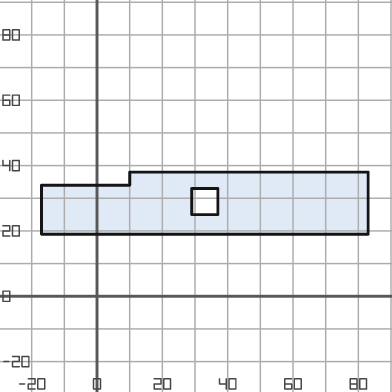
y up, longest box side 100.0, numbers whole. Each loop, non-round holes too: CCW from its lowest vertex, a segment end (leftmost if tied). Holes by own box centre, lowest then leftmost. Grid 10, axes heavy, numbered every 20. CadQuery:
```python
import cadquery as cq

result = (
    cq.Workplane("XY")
    .moveTo(-17.0, 19.0)
    .lineTo(83.0, 19.0)
    .lineTo(83.0, 38.0)
    .lineTo(10.0, 38.0)
    .lineTo(10.0, 34.0)
    .lineTo(-17.0, 34.0)
    .close()
    .moveTo(29.0, 25.0)
    .lineTo(37.0, 25.0)
    .lineTo(37.0, 33.0)
    .lineTo(29.0, 33.0)
    .close()
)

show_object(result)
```